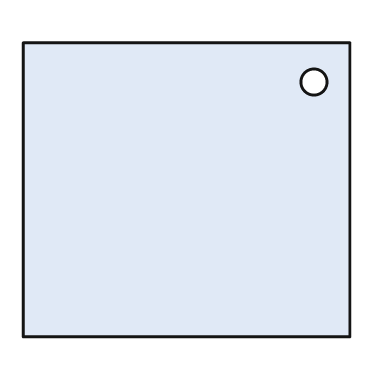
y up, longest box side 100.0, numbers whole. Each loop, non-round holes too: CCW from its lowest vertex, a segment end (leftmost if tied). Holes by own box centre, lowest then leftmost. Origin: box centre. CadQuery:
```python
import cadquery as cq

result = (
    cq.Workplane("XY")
    .moveTo(-50.0, -45.0)
    .lineTo(50.0, -45.0)
    .lineTo(50.0, 45.0)
    .lineTo(-50.0, 45.0)
    .close()
    .moveTo(39.0, 33.0)
    .circle(4.0)
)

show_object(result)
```